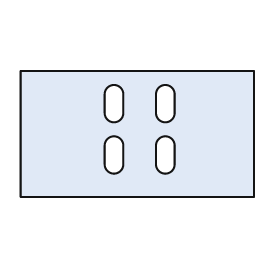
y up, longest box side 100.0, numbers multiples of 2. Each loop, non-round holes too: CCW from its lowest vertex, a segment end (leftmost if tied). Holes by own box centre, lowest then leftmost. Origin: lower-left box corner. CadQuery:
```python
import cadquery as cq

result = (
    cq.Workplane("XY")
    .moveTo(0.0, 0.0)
    .lineTo(100.0, 0.0)
    .lineTo(100.0, 54.0)
    .lineTo(0.0, 54.0)
    .close()
    .moveTo(36.0, 14.0)
    .threePointArc((40.0, 10.0), (44.0, 14.0))
    .lineTo(44.0, 22.0)
    .threePointArc((40.0, 26.0), (36.0, 22.0))
    .close()
    .moveTo(58.0, 14.0)
    .threePointArc((62.0, 10.0), (66.0, 14.0))
    .lineTo(66.0, 22.0)
    .threePointArc((62.0, 26.0), (58.0, 22.0))
    .close()
    .moveTo(36.0, 36.0)
    .threePointArc((40.0, 32.0), (44.0, 36.0))
    .lineTo(44.0, 44.0)
    .threePointArc((40.0, 48.0), (36.0, 44.0))
    .close()
    .moveTo(58.0, 36.0)
    .threePointArc((62.0, 32.0), (66.0, 36.0))
    .lineTo(66.0, 44.0)
    .threePointArc((62.0, 48.0), (58.0, 44.0))
    .close()
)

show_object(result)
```